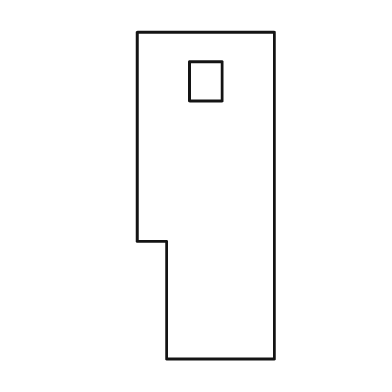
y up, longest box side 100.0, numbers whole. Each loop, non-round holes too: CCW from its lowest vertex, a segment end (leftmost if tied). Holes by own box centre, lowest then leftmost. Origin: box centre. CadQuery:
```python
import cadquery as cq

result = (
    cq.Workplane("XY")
    .moveTo(-12.0, -50.0)
    .lineTo(21.0, -50.0)
    .lineTo(21.0, 50.0)
    .lineTo(-21.0, 50.0)
    .lineTo(-21.0, -14.0)
    .lineTo(-12.0, -14.0)
    .close()
    .moveTo(-5.0, 29.0)
    .lineTo(5.0, 29.0)
    .lineTo(5.0, 41.0)
    .lineTo(-5.0, 41.0)
    .close()
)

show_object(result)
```